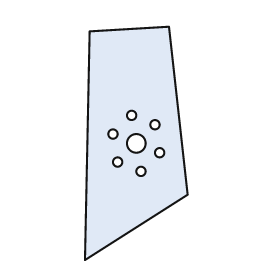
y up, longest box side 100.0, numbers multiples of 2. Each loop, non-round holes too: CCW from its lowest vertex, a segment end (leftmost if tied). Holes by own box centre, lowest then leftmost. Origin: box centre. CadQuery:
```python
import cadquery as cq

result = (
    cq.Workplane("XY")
    .moveTo(-22.0, -50.0)
    .lineTo(22.0, -22.0)
    .lineTo(14.0, 50.0)
    .lineTo(-20.0, 48.0)
    .close()
    .moveTo(2.0, -12.0)
    .circle(2.0)
    .moveTo(-8.0, -8.0)
    .circle(2.0)
    .moveTo(10.0, -4.0)
    .circle(2.0)
    .moveTo(0.0, 0.0)
    .circle(4.0)
    .moveTo(-10.0, 4.0)
    .circle(2.0)
    .moveTo(8.0, 8.0)
    .circle(2.0)
    .moveTo(-2.0, 12.0)
    .circle(2.0)
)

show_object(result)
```